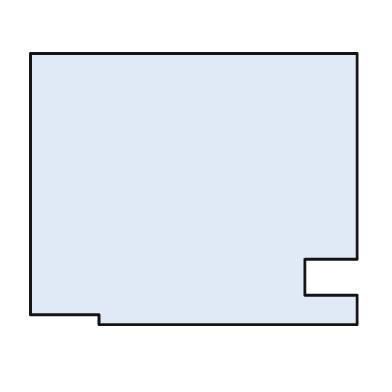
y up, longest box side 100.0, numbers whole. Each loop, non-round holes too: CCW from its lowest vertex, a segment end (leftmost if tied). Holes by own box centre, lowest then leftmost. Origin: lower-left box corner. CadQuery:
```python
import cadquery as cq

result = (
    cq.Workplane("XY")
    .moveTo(21.0, 0.0)
    .lineTo(100.0, 0.0)
    .lineTo(100.0, 9.0)
    .lineTo(84.0, 9.0)
    .lineTo(84.0, 20.0)
    .lineTo(100.0, 20.0)
    .lineTo(100.0, 83.0)
    .lineTo(0.0, 83.0)
    .lineTo(0.0, 3.0)
    .lineTo(21.0, 3.0)
    .close()
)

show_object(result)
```